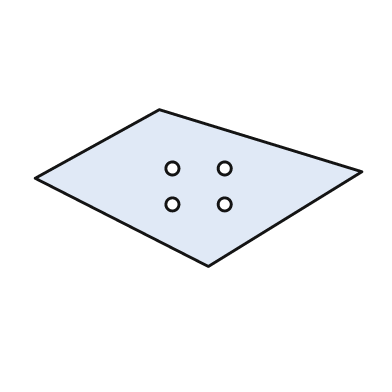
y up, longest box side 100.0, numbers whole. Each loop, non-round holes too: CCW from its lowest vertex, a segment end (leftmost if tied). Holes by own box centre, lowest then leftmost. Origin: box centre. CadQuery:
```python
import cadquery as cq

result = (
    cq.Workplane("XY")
    .moveTo(3.0, -24.0)
    .lineTo(50.0, 5.0)
    .lineTo(-12.0, 24.0)
    .lineTo(-50.0, 3.0)
    .close()
    .moveTo(-8.0, -5.0)
    .circle(2.0)
    .moveTo(8.0, -5.0)
    .circle(2.0)
    .moveTo(-8.0, 6.0)
    .circle(2.0)
    .moveTo(8.0, 6.0)
    .circle(2.0)
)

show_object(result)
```